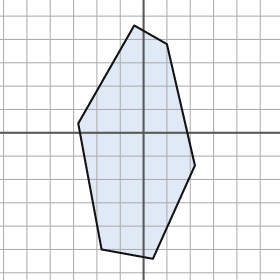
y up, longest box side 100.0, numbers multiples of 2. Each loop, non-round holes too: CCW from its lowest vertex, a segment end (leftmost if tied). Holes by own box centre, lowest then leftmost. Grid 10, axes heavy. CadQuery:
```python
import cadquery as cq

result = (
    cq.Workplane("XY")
    .moveTo(4.0, -54.0)
    .lineTo(22.0, -14.0)
    .lineTo(10.0, 38.0)
    .lineTo(-4.0, 46.0)
    .lineTo(-28.0, 4.0)
    .lineTo(-18.0, -50.0)
    .close()
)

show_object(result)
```